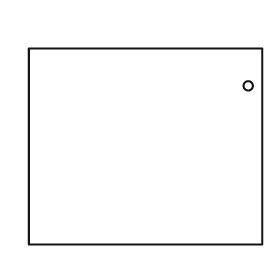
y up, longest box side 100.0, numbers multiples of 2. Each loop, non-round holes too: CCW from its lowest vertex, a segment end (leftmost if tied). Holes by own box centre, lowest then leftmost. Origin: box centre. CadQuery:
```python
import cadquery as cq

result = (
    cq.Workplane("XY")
    .moveTo(-50.0, -42.0)
    .lineTo(50.0, -42.0)
    .lineTo(50.0, 42.0)
    .lineTo(-50.0, 42.0)
    .close()
    .moveTo(44.0, 26.0)
    .circle(2.0)
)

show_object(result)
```